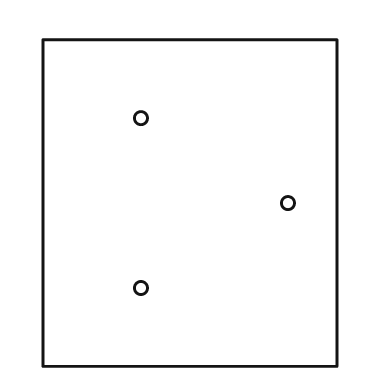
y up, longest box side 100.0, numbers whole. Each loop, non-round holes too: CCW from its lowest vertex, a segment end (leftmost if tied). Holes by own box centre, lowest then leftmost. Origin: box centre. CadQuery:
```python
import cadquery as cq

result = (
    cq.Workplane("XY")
    .moveTo(-45.0, -50.0)
    .lineTo(45.0, -50.0)
    .lineTo(45.0, 50.0)
    .lineTo(-45.0, 50.0)
    .close()
    .moveTo(-15.0, -26.0)
    .circle(2.0)
    .moveTo(30.0, 0.0)
    .circle(2.0)
    .moveTo(-15.0, 26.0)
    .circle(2.0)
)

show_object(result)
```